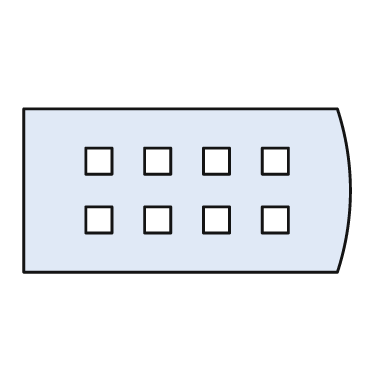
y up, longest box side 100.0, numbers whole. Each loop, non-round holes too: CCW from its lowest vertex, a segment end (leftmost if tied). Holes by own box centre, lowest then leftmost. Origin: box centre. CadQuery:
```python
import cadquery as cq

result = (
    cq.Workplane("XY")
    .moveTo(-50.0, -25.0)
    .lineTo(46.0, -25.0)
    .threePointArc((50.0, 0.0), (46.0, 25.0))
    .lineTo(-50.0, 25.0)
    .close()
    .moveTo(-31.0, -13.0)
    .lineTo(-23.0, -13.0)
    .lineTo(-23.0, -5.0)
    .lineTo(-31.0, -5.0)
    .close()
    .moveTo(-13.0, -13.0)
    .lineTo(-5.0, -13.0)
    .lineTo(-5.0, -5.0)
    .lineTo(-13.0, -5.0)
    .close()
    .moveTo(5.0, -13.0)
    .lineTo(13.0, -13.0)
    .lineTo(13.0, -5.0)
    .lineTo(5.0, -5.0)
    .close()
    .moveTo(23.0, -13.0)
    .lineTo(31.0, -13.0)
    .lineTo(31.0, -5.0)
    .lineTo(23.0, -5.0)
    .close()
    .moveTo(-31.0, 5.0)
    .lineTo(-23.0, 5.0)
    .lineTo(-23.0, 13.0)
    .lineTo(-31.0, 13.0)
    .close()
    .moveTo(-13.0, 5.0)
    .lineTo(-5.0, 5.0)
    .lineTo(-5.0, 13.0)
    .lineTo(-13.0, 13.0)
    .close()
    .moveTo(5.0, 5.0)
    .lineTo(13.0, 5.0)
    .lineTo(13.0, 13.0)
    .lineTo(5.0, 13.0)
    .close()
    .moveTo(23.0, 5.0)
    .lineTo(31.0, 5.0)
    .lineTo(31.0, 13.0)
    .lineTo(23.0, 13.0)
    .close()
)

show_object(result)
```